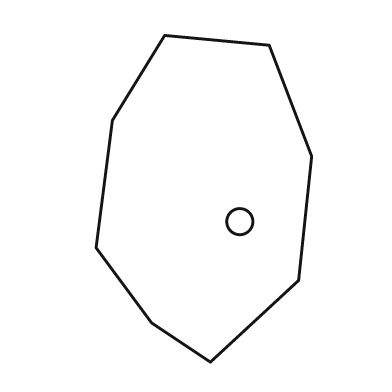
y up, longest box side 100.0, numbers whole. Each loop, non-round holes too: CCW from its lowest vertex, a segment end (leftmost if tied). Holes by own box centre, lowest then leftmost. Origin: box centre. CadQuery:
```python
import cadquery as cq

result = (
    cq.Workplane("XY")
    .moveTo(2.0, -50.0)
    .lineTo(29.0, -25.0)
    .lineTo(33.0, 13.0)
    .lineTo(20.0, 47.0)
    .lineTo(-12.0, 50.0)
    .lineTo(-28.0, 24.0)
    .lineTo(-33.0, -15.0)
    .lineTo(-16.0, -38.0)
    .close()
    .moveTo(11.0, -7.0)
    .circle(4.0)
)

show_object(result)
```